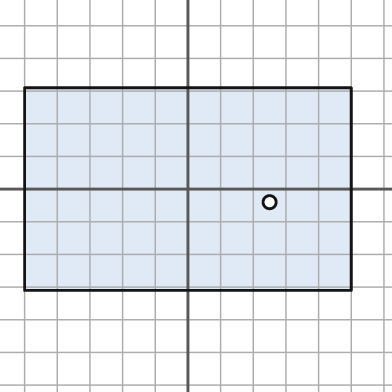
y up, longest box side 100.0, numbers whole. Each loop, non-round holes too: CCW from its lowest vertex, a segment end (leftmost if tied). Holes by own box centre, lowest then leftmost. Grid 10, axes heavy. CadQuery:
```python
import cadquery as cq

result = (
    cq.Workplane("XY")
    .moveTo(-50.0, -31.0)
    .lineTo(50.0, -31.0)
    .lineTo(50.0, 31.0)
    .lineTo(-50.0, 31.0)
    .close()
    .moveTo(25.0, -4.0)
    .circle(2.0)
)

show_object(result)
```